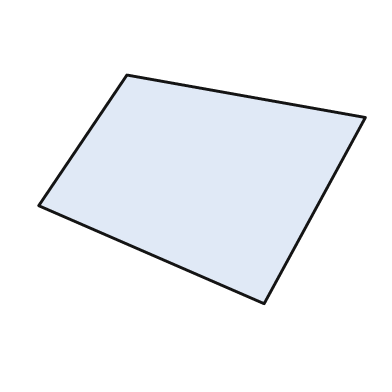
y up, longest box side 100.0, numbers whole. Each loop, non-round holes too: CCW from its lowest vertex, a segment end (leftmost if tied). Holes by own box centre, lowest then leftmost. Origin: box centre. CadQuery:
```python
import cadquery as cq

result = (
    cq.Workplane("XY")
    .moveTo(19.0, -35.0)
    .lineTo(50.0, 22.0)
    .lineTo(-23.0, 35.0)
    .lineTo(-50.0, -5.0)
    .close()
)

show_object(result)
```